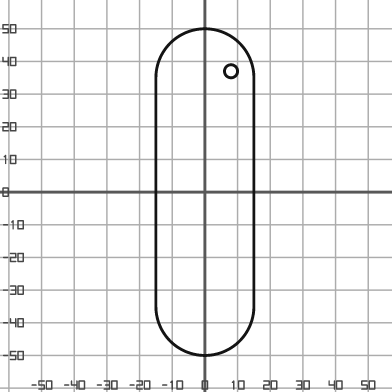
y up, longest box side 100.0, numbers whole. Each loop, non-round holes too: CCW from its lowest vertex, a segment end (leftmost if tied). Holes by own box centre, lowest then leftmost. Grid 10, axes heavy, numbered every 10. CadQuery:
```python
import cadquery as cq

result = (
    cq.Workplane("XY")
    .moveTo(-15.0, -35.0)
    .threePointArc((0.0, -50.0), (15.0, -35.0))
    .lineTo(15.0, 35.0)
    .threePointArc((0.0, 50.0), (-15.0, 35.0))
    .close()
    .moveTo(8.0, 37.0)
    .circle(2.0)
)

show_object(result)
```